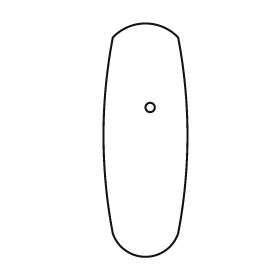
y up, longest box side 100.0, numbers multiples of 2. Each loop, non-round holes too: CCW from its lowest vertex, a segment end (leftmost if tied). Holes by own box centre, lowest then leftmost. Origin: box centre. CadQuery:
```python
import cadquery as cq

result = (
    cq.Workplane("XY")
    .moveTo(-14.0, -40.0)
    .threePointArc((0.0, -50.0), (14.0, -40.0))
    .threePointArc((18.0, 2.0), (14.0, 44.0))
    .threePointArc((0.0, 50.0), (-14.0, 44.0))
    .threePointArc((-18.0, 2.0), (-14.0, -40.0))
    .close()
    .moveTo(2.0, 14.0)
    .circle(2.0)
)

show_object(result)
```